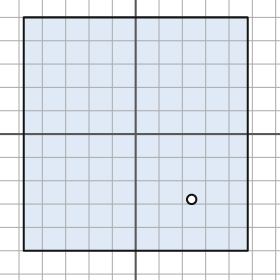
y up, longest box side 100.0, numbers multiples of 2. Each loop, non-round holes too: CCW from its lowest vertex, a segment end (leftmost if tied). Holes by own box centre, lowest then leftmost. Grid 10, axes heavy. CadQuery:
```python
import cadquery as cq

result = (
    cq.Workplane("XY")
    .moveTo(-48.0, -50.0)
    .lineTo(48.0, -50.0)
    .lineTo(48.0, 50.0)
    .lineTo(-48.0, 50.0)
    .close()
    .moveTo(24.0, -28.0)
    .circle(2.0)
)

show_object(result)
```